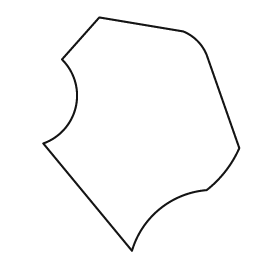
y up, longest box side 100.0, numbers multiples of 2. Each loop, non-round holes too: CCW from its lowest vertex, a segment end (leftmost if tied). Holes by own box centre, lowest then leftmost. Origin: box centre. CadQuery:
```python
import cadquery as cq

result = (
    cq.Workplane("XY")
    .moveTo(-4.0, -50.0)
    .threePointArc((8.0, -32.0), (28.0, -24.0))
    .threePointArc((36.0, -16.0), (42.0, -6.0))
    .lineTo(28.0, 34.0)
    .threePointArc((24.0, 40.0), (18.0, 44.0))
    .lineTo(-18.0, 50.0)
    .lineTo(-34.0, 32.0)
    .threePointArc((-28.0, 12.0), (-42.0, -4.0))
    .close()
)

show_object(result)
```